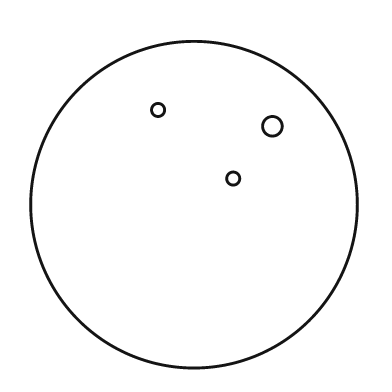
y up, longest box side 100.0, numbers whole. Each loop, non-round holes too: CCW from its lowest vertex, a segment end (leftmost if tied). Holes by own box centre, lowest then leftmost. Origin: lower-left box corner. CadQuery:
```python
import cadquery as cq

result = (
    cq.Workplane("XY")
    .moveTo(50.0, 50.0)
    .circle(50.0)
    .moveTo(62.0, 58.0)
    .circle(2.0)
    .moveTo(74.0, 74.0)
    .circle(3.0)
    .moveTo(39.0, 79.0)
    .circle(2.0)
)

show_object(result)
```